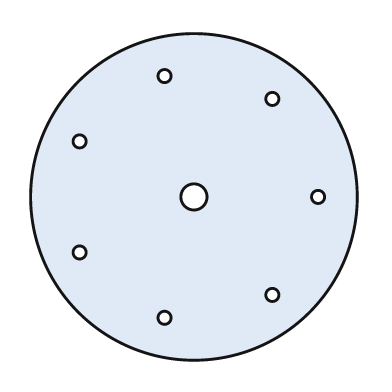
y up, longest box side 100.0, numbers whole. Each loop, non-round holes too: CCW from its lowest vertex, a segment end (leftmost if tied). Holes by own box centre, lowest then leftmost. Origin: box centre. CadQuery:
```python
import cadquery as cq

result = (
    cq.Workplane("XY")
    .moveTo(0.0, 0.0)
    .circle(50.0)
    .moveTo(-9.0, -37.0)
    .circle(2.0)
    .moveTo(24.0, -30.0)
    .circle(2.0)
    .moveTo(-35.0, -17.0)
    .circle(2.0)
    .moveTo(0.0, 0.0)
    .circle(4.0)
    .moveTo(38.0, 0.0)
    .circle(2.0)
    .moveTo(-35.0, 17.0)
    .circle(2.0)
    .moveTo(24.0, 30.0)
    .circle(2.0)
    .moveTo(-9.0, 37.0)
    .circle(2.0)
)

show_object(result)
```